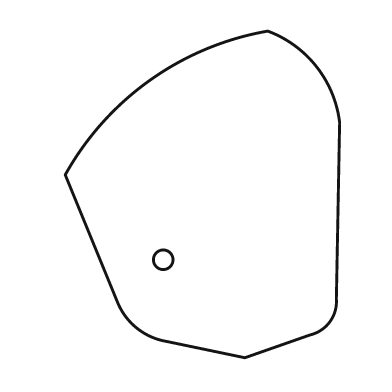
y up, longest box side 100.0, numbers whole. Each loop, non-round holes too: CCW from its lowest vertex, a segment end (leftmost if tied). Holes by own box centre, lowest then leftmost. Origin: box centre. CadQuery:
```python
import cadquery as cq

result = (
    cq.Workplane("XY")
    .moveTo(13.0, -50.0)
    .lineTo(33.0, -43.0)
    .threePointArc((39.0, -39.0), (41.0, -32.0))
    .lineTo(42.0, 22.0)
    .threePointArc((35.0, 39.0), (20.0, 50.0))
    .threePointArc((-16.0, 35.0), (-42.0, 6.0))
    .lineTo(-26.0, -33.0)
    .threePointArc((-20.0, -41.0), (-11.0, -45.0))
    .close()
    .moveTo(-12.0, -20.0)
    .circle(3.0)
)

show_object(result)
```